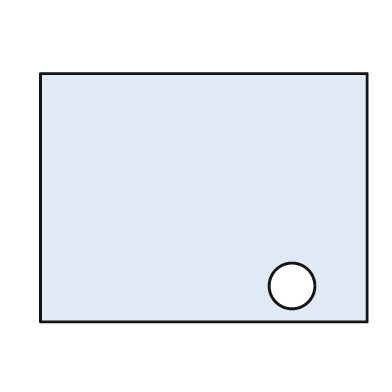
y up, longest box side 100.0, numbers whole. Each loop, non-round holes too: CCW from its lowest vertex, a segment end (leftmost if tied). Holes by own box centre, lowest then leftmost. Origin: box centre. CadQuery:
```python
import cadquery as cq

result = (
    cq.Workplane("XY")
    .moveTo(-50.0, -38.0)
    .lineTo(50.0, -38.0)
    .lineTo(50.0, 38.0)
    .lineTo(-50.0, 38.0)
    .close()
    .moveTo(27.0, -27.0)
    .circle(7.0)
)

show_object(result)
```